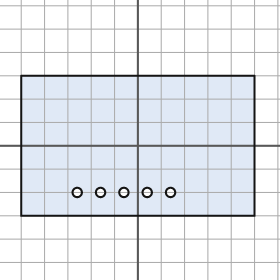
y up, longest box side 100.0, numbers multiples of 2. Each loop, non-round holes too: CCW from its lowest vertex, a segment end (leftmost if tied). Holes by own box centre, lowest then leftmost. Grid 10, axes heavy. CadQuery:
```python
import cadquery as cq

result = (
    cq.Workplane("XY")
    .moveTo(-50.0, -30.0)
    .lineTo(50.0, -30.0)
    .lineTo(50.0, 30.0)
    .lineTo(-50.0, 30.0)
    .close()
    .moveTo(-26.0, -20.0)
    .circle(2.0)
    .moveTo(-16.0, -20.0)
    .circle(2.0)
    .moveTo(-6.0, -20.0)
    .circle(2.0)
    .moveTo(4.0, -20.0)
    .circle(2.0)
    .moveTo(14.0, -20.0)
    .circle(2.0)
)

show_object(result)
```